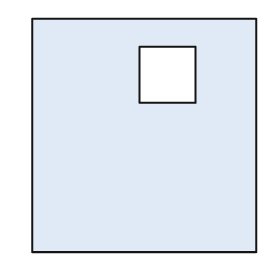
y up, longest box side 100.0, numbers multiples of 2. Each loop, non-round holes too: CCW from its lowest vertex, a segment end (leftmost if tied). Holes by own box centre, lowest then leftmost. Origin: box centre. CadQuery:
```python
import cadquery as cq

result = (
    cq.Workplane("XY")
    .moveTo(-48.0, -50.0)
    .lineTo(48.0, -50.0)
    .lineTo(48.0, 50.0)
    .lineTo(-48.0, 50.0)
    .close()
    .moveTo(-2.0, 14.0)
    .lineTo(22.0, 14.0)
    .lineTo(22.0, 38.0)
    .lineTo(-2.0, 38.0)
    .close()
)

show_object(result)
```